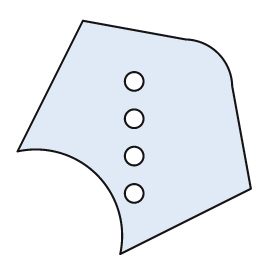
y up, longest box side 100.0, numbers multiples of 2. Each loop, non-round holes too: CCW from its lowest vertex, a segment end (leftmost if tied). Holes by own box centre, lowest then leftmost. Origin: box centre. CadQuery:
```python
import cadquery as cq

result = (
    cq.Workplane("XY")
    .moveTo(-6.0, -50.0)
    .lineTo(50.0, -22.0)
    .lineTo(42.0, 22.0)
    .threePointArc((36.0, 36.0), (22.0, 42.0))
    .lineTo(-22.0, 50.0)
    .lineTo(-50.0, -6.0)
    .threePointArc((-16.0, -16.0), (-6.0, -50.0))
    .close()
    .moveTo(0.0, -24.0)
    .circle(4.0)
    .moveTo(0.0, -8.0)
    .circle(4.0)
    .moveTo(0.0, 8.0)
    .circle(4.0)
    .moveTo(0.0, 24.0)
    .circle(4.0)
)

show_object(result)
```